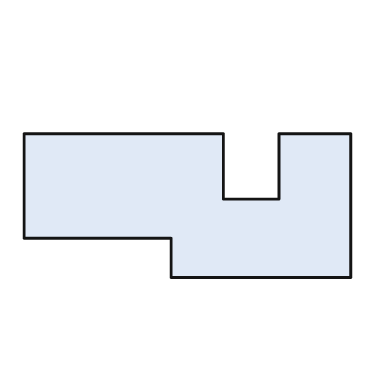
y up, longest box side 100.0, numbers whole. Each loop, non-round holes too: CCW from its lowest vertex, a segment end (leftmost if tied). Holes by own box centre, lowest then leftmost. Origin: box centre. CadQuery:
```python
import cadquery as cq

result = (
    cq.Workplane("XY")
    .moveTo(-5.0, -22.0)
    .lineTo(50.0, -22.0)
    .lineTo(50.0, 22.0)
    .lineTo(28.0, 22.0)
    .lineTo(28.0, 2.0)
    .lineTo(11.0, 2.0)
    .lineTo(11.0, 22.0)
    .lineTo(-50.0, 22.0)
    .lineTo(-50.0, -10.0)
    .lineTo(-5.0, -10.0)
    .close()
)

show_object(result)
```